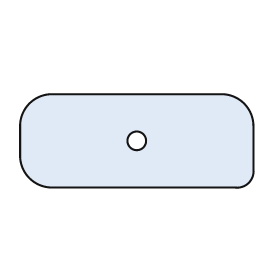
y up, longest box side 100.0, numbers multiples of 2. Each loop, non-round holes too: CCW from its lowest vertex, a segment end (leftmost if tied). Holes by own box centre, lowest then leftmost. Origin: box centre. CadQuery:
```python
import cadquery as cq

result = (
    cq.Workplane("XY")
    .moveTo(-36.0, -20.0)
    .lineTo(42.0, -20.0)
    .threePointArc((48.0, -18.0), (50.0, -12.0))
    .lineTo(50.0, 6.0)
    .threePointArc((46.0, 16.0), (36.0, 20.0))
    .lineTo(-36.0, 20.0)
    .threePointArc((-46.0, 16.0), (-50.0, 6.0))
    .lineTo(-50.0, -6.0)
    .threePointArc((-46.0, -16.0), (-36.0, -20.0))
    .close()
    .moveTo(0.0, 0.0)
    .circle(4.0)
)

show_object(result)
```